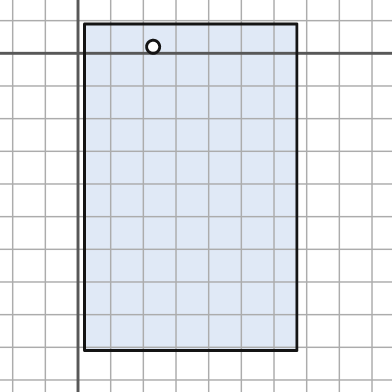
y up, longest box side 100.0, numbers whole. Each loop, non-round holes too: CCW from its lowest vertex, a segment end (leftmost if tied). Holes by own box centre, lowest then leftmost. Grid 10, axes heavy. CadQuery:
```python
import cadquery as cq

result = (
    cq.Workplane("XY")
    .moveTo(2.0, -91.0)
    .lineTo(67.0, -91.0)
    .lineTo(67.0, 9.0)
    .lineTo(2.0, 9.0)
    .close()
    .moveTo(23.0, 2.0)
    .circle(2.0)
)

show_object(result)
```